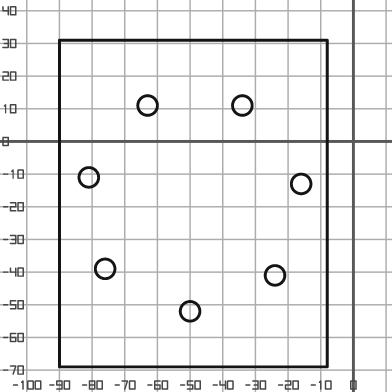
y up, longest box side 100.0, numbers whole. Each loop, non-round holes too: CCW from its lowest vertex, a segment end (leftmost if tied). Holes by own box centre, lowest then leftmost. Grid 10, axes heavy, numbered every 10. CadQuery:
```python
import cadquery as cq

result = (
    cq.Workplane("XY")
    .moveTo(-90.0, -69.0)
    .lineTo(-8.0, -69.0)
    .lineTo(-8.0, 31.0)
    .lineTo(-90.0, 31.0)
    .close()
    .moveTo(-50.0, -52.0)
    .circle(3.0)
    .moveTo(-24.0, -41.0)
    .circle(3.0)
    .moveTo(-76.0, -39.0)
    .circle(3.0)
    .moveTo(-16.0, -13.0)
    .circle(3.0)
    .moveTo(-81.0, -11.0)
    .circle(3.0)
    .moveTo(-63.0, 11.0)
    .circle(3.0)
    .moveTo(-34.0, 11.0)
    .circle(3.0)
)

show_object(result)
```